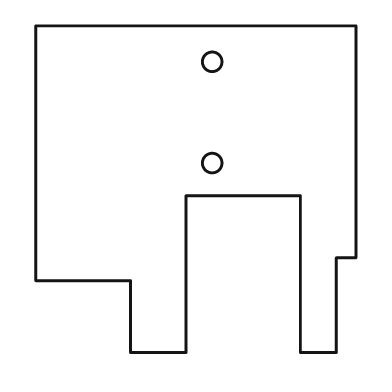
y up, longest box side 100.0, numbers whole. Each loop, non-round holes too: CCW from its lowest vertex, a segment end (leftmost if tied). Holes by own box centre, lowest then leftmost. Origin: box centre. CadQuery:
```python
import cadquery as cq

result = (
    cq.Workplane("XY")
    .moveTo(-20.0, -50.0)
    .lineTo(-3.0, -50.0)
    .lineTo(-3.0, -2.0)
    .lineTo(32.0, -2.0)
    .lineTo(32.0, -50.0)
    .lineTo(43.0, -50.0)
    .lineTo(43.0, -21.0)
    .lineTo(49.0, -21.0)
    .lineTo(49.0, 50.0)
    .lineTo(-49.0, 50.0)
    .lineTo(-49.0, -28.0)
    .lineTo(-20.0, -28.0)
    .close()
    .moveTo(5.0, 8.0)
    .circle(3.0)
    .moveTo(5.0, 39.0)
    .circle(3.0)
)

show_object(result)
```